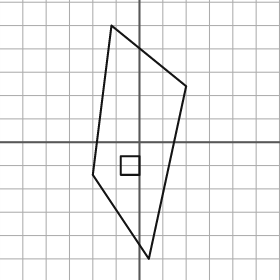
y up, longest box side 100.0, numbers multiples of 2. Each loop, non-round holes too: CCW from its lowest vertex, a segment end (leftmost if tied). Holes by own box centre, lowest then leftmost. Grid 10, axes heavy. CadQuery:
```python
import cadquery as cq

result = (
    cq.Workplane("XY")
    .moveTo(4.0, -50.0)
    .lineTo(20.0, 24.0)
    .lineTo(-12.0, 50.0)
    .lineTo(-20.0, -14.0)
    .close()
    .moveTo(-8.0, -14.0)
    .lineTo(0.0, -14.0)
    .lineTo(0.0, -6.0)
    .lineTo(-8.0, -6.0)
    .close()
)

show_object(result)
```